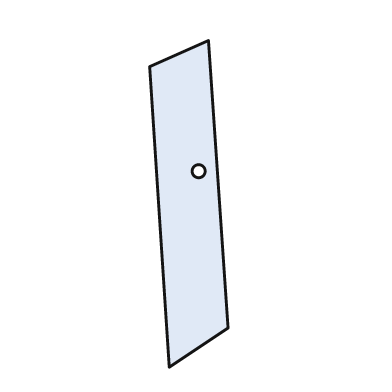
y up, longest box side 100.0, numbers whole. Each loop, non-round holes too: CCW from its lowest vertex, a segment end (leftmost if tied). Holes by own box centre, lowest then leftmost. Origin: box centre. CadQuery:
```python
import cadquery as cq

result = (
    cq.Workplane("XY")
    .moveTo(-6.0, -50.0)
    .lineTo(12.0, -38.0)
    .lineTo(6.0, 50.0)
    .lineTo(-12.0, 42.0)
    .close()
    .moveTo(3.0, 10.0)
    .circle(2.0)
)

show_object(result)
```